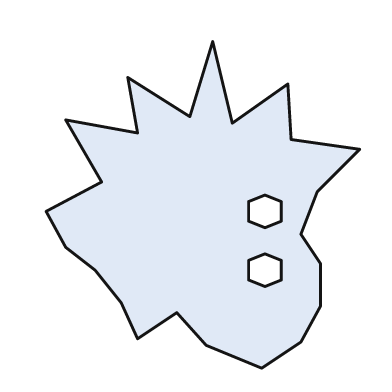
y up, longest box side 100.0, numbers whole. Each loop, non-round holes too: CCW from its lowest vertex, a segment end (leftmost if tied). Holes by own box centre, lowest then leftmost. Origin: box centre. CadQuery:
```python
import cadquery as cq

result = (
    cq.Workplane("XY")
    .moveTo(18.0, -50.0)
    .lineTo(30.0, -42.0)
    .lineTo(36.0, -31.0)
    .lineTo(36.0, -18.0)
    .lineTo(30.0, -9.0)
    .lineTo(35.0, 4.0)
    .lineTo(48.0, 17.0)
    .lineTo(27.0, 20.0)
    .lineTo(26.0, 37.0)
    .lineTo(9.0, 25.0)
    .lineTo(3.0, 50.0)
    .lineTo(-4.0, 27.0)
    .lineTo(-23.0, 39.0)
    .lineTo(-20.0, 22.0)
    .lineTo(-42.0, 26.0)
    .lineTo(-31.0, 7.0)
    .lineTo(-48.0, -2.0)
    .lineTo(-42.0, -13.0)
    .lineTo(-33.0, -20.0)
    .lineTo(-25.0, -30.0)
    .lineTo(-20.0, -41.0)
    .lineTo(-8.0, -33.0)
    .lineTo(1.0, -43.0)
    .close()
    .moveTo(19.0, -25.0)
    .lineTo(24.0, -23.0)
    .lineTo(24.0, -17.0)
    .lineTo(19.0, -15.0)
    .lineTo(14.0, -17.0)
    .lineTo(14.0, -23.0)
    .close()
    .moveTo(19.0, -7.0)
    .lineTo(24.0, -5.0)
    .lineTo(24.0, 1.0)
    .lineTo(19.0, 3.0)
    .lineTo(14.0, 1.0)
    .lineTo(14.0, -5.0)
    .close()
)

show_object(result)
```